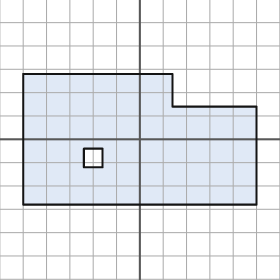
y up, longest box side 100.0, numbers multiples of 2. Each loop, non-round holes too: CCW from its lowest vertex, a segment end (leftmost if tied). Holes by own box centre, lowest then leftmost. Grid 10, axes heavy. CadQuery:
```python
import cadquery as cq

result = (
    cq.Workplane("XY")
    .moveTo(-50.0, -28.0)
    .lineTo(50.0, -28.0)
    .lineTo(50.0, 14.0)
    .lineTo(14.0, 14.0)
    .lineTo(14.0, 28.0)
    .lineTo(-50.0, 28.0)
    .close()
    .moveTo(-24.0, -12.0)
    .lineTo(-16.0, -12.0)
    .lineTo(-16.0, -4.0)
    .lineTo(-24.0, -4.0)
    .close()
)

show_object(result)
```